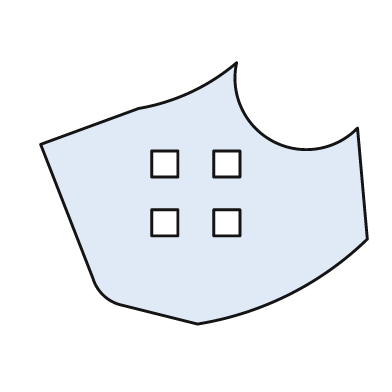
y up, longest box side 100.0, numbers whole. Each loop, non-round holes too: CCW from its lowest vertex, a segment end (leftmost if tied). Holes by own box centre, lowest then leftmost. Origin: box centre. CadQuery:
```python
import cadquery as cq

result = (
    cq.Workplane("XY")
    .moveTo(-2.0, -40.0)
    .threePointArc((26.0, -31.0), (50.0, -14.0))
    .lineTo(47.0, 20.0)
    .threePointArc((21.0, 16.0), (10.0, 40.0))
    .threePointArc((-4.0, 31.0), (-20.0, 26.0))
    .lineTo(-50.0, 15.0)
    .lineTo(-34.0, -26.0)
    .threePointArc((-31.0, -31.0), (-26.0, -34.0))
    .close()
    .moveTo(-16.0, -13.0)
    .lineTo(-8.0, -13.0)
    .lineTo(-8.0, -5.0)
    .lineTo(-16.0, -5.0)
    .close()
    .moveTo(3.0, -13.0)
    .lineTo(11.0, -13.0)
    .lineTo(11.0, -5.0)
    .lineTo(3.0, -5.0)
    .close()
    .moveTo(-16.0, 5.0)
    .lineTo(-8.0, 5.0)
    .lineTo(-8.0, 13.0)
    .lineTo(-16.0, 13.0)
    .close()
    .moveTo(3.0, 5.0)
    .lineTo(11.0, 5.0)
    .lineTo(11.0, 13.0)
    .lineTo(3.0, 13.0)
    .close()
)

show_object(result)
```